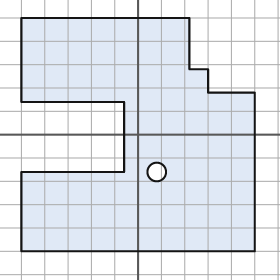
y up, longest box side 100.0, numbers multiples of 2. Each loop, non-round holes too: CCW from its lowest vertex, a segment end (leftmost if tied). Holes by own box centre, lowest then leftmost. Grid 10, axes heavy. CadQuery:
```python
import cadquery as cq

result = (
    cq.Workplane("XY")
    .moveTo(-50.0, -50.0)
    .lineTo(50.0, -50.0)
    .lineTo(50.0, 18.0)
    .lineTo(30.0, 18.0)
    .lineTo(30.0, 28.0)
    .lineTo(22.0, 28.0)
    .lineTo(22.0, 50.0)
    .lineTo(-50.0, 50.0)
    .lineTo(-50.0, 14.0)
    .lineTo(-6.0, 14.0)
    .lineTo(-6.0, -16.0)
    .lineTo(-50.0, -16.0)
    .close()
    .moveTo(8.0, -16.0)
    .circle(4.0)
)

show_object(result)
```